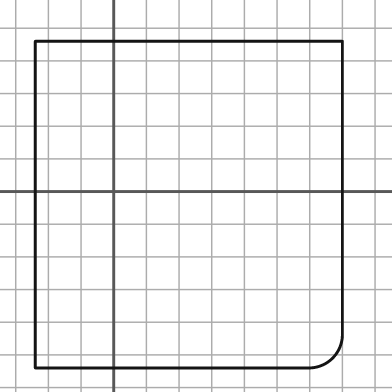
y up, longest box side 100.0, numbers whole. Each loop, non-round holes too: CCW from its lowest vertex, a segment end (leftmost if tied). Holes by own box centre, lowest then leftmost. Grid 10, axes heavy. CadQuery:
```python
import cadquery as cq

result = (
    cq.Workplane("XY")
    .moveTo(-24.0, -54.0)
    .lineTo(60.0, -54.0)
    .threePointArc((67.0, -51.0), (70.0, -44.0))
    .lineTo(70.0, 46.0)
    .lineTo(-24.0, 46.0)
    .close()
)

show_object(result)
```